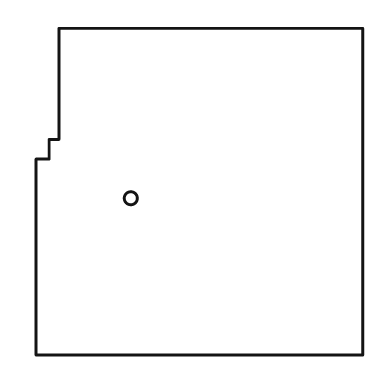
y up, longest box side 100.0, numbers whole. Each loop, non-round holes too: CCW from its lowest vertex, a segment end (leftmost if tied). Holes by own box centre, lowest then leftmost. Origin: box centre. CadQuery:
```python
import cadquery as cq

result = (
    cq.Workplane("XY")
    .moveTo(-50.0, -50.0)
    .lineTo(50.0, -50.0)
    .lineTo(50.0, 50.0)
    .lineTo(-43.0, 50.0)
    .lineTo(-43.0, 16.0)
    .lineTo(-46.0, 16.0)
    .lineTo(-46.0, 10.0)
    .lineTo(-50.0, 10.0)
    .close()
    .moveTo(-21.0, -2.0)
    .circle(2.0)
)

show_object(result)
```